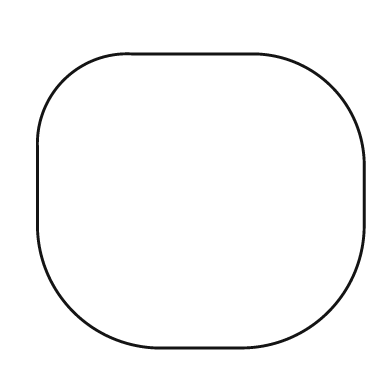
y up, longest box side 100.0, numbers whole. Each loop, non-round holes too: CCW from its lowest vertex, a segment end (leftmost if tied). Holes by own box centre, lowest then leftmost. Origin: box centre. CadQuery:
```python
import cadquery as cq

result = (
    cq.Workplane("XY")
    .moveTo(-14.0, -45.0)
    .lineTo(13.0, -45.0)
    .threePointArc((39.0, -34.0), (50.0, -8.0))
    .lineTo(50.0, 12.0)
    .threePointArc((40.0, 35.0), (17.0, 45.0))
    .lineTo(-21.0, 45.0)
    .threePointArc((-42.0, 37.0), (-50.0, 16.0))
    .lineTo(-50.0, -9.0)
    .threePointArc((-39.0, -34.0), (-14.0, -45.0))
    .close()
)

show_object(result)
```